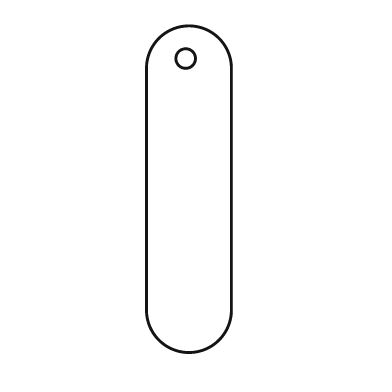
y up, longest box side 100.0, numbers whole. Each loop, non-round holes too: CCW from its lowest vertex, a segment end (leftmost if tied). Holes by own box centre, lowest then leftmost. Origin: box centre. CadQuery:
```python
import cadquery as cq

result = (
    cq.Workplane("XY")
    .moveTo(-13.0, -37.0)
    .threePointArc((0.0, -50.0), (13.0, -37.0))
    .lineTo(13.0, 37.0)
    .threePointArc((0.0, 50.0), (-13.0, 37.0))
    .close()
    .moveTo(-1.0, 40.0)
    .circle(3.0)
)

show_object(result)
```